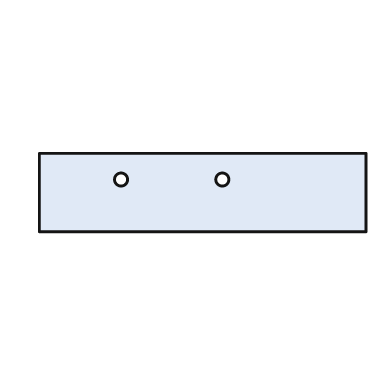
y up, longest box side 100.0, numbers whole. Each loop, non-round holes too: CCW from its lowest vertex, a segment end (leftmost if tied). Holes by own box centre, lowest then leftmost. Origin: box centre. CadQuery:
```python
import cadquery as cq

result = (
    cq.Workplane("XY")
    .moveTo(-50.0, -12.0)
    .lineTo(50.0, -12.0)
    .lineTo(50.0, 12.0)
    .lineTo(-50.0, 12.0)
    .close()
    .moveTo(-25.0, 4.0)
    .circle(2.0)
    .moveTo(6.0, 4.0)
    .circle(2.0)
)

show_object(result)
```